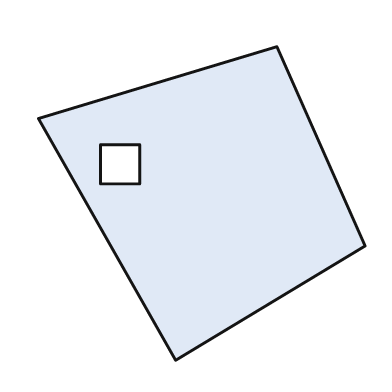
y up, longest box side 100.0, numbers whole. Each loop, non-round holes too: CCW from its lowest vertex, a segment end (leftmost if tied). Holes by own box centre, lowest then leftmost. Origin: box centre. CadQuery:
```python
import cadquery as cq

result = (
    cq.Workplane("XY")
    .moveTo(-8.0, -48.0)
    .lineTo(50.0, -13.0)
    .lineTo(23.0, 48.0)
    .lineTo(-50.0, 26.0)
    .close()
    .moveTo(-31.0, 6.0)
    .lineTo(-19.0, 6.0)
    .lineTo(-19.0, 18.0)
    .lineTo(-31.0, 18.0)
    .close()
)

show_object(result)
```